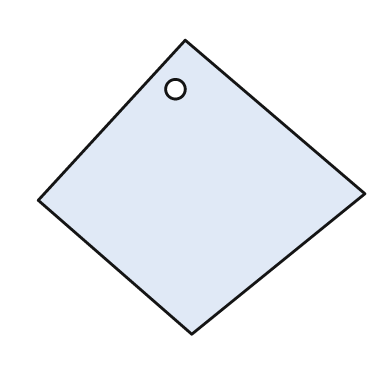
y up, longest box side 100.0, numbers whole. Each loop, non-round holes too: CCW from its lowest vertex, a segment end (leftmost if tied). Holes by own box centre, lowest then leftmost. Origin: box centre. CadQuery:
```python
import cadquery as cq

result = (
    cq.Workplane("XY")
    .moveTo(-3.0, -45.0)
    .lineTo(50.0, -2.0)
    .lineTo(-5.0, 45.0)
    .lineTo(-50.0, -4.0)
    .close()
    .moveTo(-8.0, 30.0)
    .circle(3.0)
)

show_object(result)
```